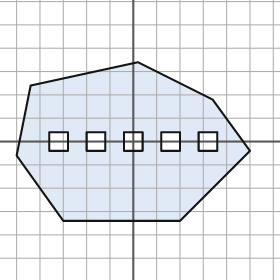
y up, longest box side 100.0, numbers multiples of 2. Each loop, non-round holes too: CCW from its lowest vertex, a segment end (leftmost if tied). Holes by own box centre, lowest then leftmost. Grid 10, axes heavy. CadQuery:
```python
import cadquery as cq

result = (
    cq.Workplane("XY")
    .moveTo(-30.0, -34.0)
    .lineTo(20.0, -34.0)
    .lineTo(50.0, -4.0)
    .lineTo(34.0, 18.0)
    .lineTo(2.0, 34.0)
    .lineTo(-44.0, 24.0)
    .lineTo(-50.0, -6.0)
    .close()
    .moveTo(-36.0, -4.0)
    .lineTo(-28.0, -4.0)
    .lineTo(-28.0, 4.0)
    .lineTo(-36.0, 4.0)
    .close()
    .moveTo(-20.0, -4.0)
    .lineTo(-12.0, -4.0)
    .lineTo(-12.0, 4.0)
    .lineTo(-20.0, 4.0)
    .close()
    .moveTo(-4.0, -4.0)
    .lineTo(4.0, -4.0)
    .lineTo(4.0, 4.0)
    .lineTo(-4.0, 4.0)
    .close()
    .moveTo(12.0, -4.0)
    .lineTo(20.0, -4.0)
    .lineTo(20.0, 4.0)
    .lineTo(12.0, 4.0)
    .close()
    .moveTo(28.0, -4.0)
    .lineTo(36.0, -4.0)
    .lineTo(36.0, 4.0)
    .lineTo(28.0, 4.0)
    .close()
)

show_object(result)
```